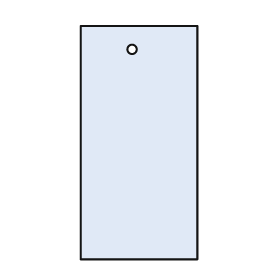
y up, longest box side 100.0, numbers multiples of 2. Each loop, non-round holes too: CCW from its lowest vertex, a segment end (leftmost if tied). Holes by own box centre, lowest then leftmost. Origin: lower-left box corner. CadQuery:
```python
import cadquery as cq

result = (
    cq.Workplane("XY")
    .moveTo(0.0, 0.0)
    .lineTo(50.0, 0.0)
    .lineTo(50.0, 100.0)
    .lineTo(0.0, 100.0)
    .close()
    .moveTo(22.0, 90.0)
    .circle(2.0)
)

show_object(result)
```